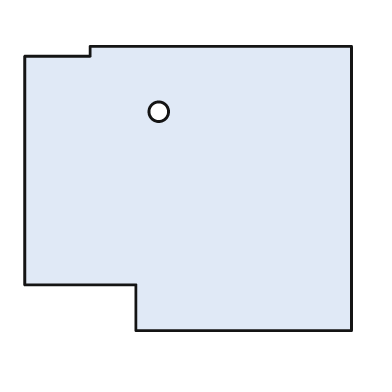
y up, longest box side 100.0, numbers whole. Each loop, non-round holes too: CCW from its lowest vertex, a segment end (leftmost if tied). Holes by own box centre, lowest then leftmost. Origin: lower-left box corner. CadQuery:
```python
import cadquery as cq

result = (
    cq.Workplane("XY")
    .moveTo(34.0, 0.0)
    .lineTo(100.0, 0.0)
    .lineTo(100.0, 87.0)
    .lineTo(20.0, 87.0)
    .lineTo(20.0, 84.0)
    .lineTo(0.0, 84.0)
    .lineTo(0.0, 14.0)
    .lineTo(34.0, 14.0)
    .close()
    .moveTo(41.0, 67.0)
    .circle(3.0)
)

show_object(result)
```